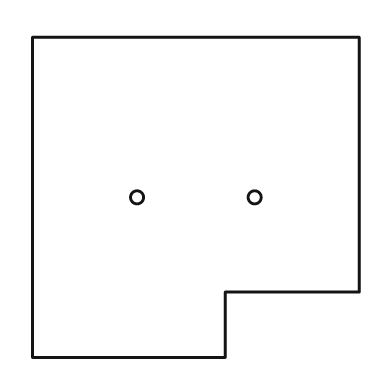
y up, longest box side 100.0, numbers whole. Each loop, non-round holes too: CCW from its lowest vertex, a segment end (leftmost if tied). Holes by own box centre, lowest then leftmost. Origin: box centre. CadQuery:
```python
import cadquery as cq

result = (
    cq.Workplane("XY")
    .moveTo(-50.0, -49.0)
    .lineTo(9.0, -49.0)
    .lineTo(9.0, -29.0)
    .lineTo(50.0, -29.0)
    .lineTo(50.0, 49.0)
    .lineTo(-50.0, 49.0)
    .close()
    .moveTo(-18.0, 0.0)
    .circle(2.0)
    .moveTo(18.0, 0.0)
    .circle(2.0)
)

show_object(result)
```